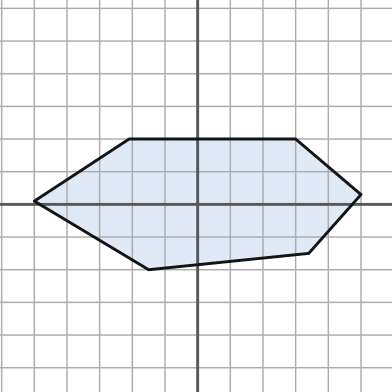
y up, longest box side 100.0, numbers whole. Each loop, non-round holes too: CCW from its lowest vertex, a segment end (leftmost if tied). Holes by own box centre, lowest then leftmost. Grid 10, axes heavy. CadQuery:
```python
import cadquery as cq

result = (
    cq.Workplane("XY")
    .moveTo(-15.0, -20.0)
    .lineTo(34.0, -15.0)
    .lineTo(50.0, 3.0)
    .lineTo(30.0, 20.0)
    .lineTo(-21.0, 20.0)
    .lineTo(-50.0, 1.0)
    .close()
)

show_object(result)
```